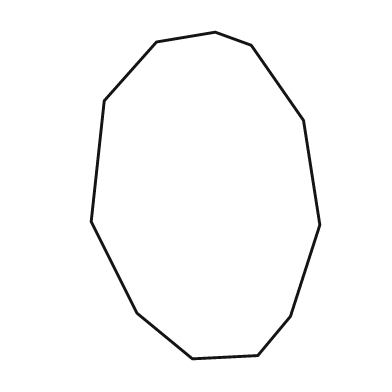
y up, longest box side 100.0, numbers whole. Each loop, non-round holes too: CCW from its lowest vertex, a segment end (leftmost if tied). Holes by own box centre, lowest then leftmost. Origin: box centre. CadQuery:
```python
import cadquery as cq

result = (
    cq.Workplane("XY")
    .moveTo(-4.0, -50.0)
    .lineTo(16.0, -49.0)
    .lineTo(26.0, -37.0)
    .lineTo(35.0, -9.0)
    .lineTo(30.0, 23.0)
    .lineTo(14.0, 46.0)
    .lineTo(3.0, 50.0)
    .lineTo(-15.0, 47.0)
    .lineTo(-31.0, 29.0)
    .lineTo(-35.0, -8.0)
    .lineTo(-21.0, -36.0)
    .close()
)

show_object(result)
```